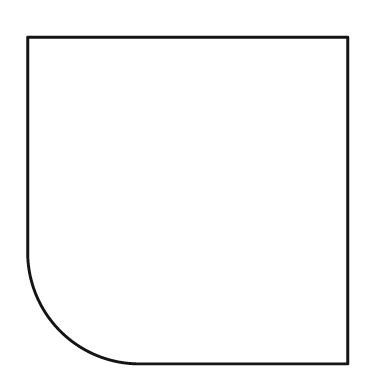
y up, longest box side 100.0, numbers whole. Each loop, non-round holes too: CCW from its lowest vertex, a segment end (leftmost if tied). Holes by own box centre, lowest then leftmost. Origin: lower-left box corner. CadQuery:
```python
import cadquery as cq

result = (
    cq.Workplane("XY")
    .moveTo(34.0, 0.0)
    .lineTo(98.0, 0.0)
    .lineTo(98.0, 100.0)
    .lineTo(0.0, 100.0)
    .lineTo(0.0, 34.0)
    .threePointArc((10.0, 10.0), (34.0, 0.0))
    .close()
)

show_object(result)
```